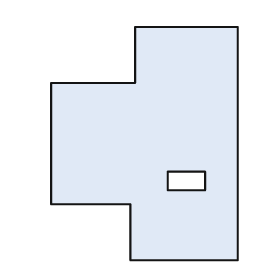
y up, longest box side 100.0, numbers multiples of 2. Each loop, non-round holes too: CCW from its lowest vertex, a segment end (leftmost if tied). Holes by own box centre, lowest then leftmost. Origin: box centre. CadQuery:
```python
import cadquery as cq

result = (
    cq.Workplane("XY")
    .moveTo(-6.0, -50.0)
    .lineTo(40.0, -50.0)
    .lineTo(40.0, 50.0)
    .lineTo(-4.0, 50.0)
    .lineTo(-4.0, 26.0)
    .lineTo(-40.0, 26.0)
    .lineTo(-40.0, -26.0)
    .lineTo(-6.0, -26.0)
    .close()
    .moveTo(10.0, -20.0)
    .lineTo(26.0, -20.0)
    .lineTo(26.0, -12.0)
    .lineTo(10.0, -12.0)
    .close()
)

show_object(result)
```